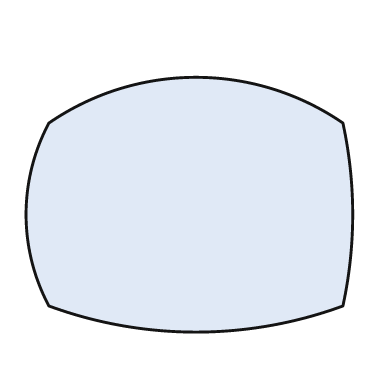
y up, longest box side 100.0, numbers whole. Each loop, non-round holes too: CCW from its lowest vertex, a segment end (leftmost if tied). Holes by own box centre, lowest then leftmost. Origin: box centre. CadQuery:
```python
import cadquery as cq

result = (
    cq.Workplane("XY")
    .moveTo(-43.0, -31.0)
    .threePointArc((2.0, -39.0), (47.0, -31.0))
    .threePointArc((50.0, -3.0), (47.0, 25.0))
    .threePointArc((2.0, 39.0), (-43.0, 25.0))
    .threePointArc((-50.0, -3.0), (-43.0, -31.0))
    .close()
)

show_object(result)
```